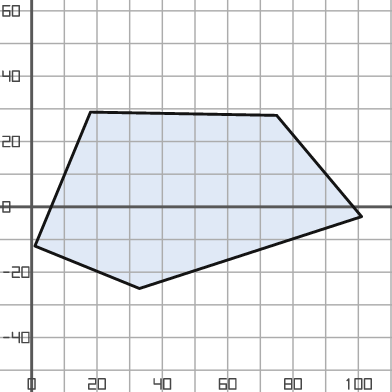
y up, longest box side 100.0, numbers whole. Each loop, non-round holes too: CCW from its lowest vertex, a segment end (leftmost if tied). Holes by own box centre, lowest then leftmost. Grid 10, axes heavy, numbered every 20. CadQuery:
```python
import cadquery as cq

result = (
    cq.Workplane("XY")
    .moveTo(33.0, -25.0)
    .lineTo(101.0, -3.0)
    .lineTo(75.0, 28.0)
    .lineTo(18.0, 29.0)
    .lineTo(1.0, -12.0)
    .close()
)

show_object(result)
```